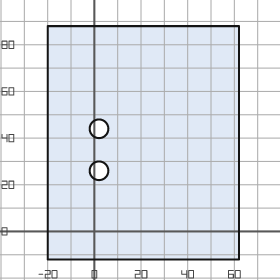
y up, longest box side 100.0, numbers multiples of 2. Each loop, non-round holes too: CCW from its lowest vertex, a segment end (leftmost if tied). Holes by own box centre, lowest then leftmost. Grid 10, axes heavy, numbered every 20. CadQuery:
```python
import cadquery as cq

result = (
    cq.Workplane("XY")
    .moveTo(-20.0, -12.0)
    .lineTo(62.0, -12.0)
    .lineTo(62.0, 88.0)
    .lineTo(-20.0, 88.0)
    .close()
    .moveTo(2.0, 26.0)
    .circle(4.0)
    .moveTo(2.0, 44.0)
    .circle(4.0)
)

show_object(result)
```